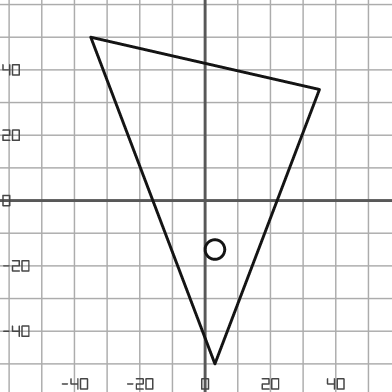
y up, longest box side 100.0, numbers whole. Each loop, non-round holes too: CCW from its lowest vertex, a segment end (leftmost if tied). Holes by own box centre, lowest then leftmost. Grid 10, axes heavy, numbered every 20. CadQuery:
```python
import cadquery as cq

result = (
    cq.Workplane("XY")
    .moveTo(3.0, -50.0)
    .lineTo(35.0, 34.0)
    .lineTo(-35.0, 50.0)
    .close()
    .moveTo(3.0, -15.0)
    .circle(3.0)
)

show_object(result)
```